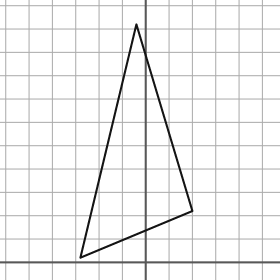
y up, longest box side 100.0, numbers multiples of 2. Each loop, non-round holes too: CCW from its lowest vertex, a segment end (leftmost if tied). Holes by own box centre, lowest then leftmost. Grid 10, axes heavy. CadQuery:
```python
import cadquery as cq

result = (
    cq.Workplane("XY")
    .moveTo(-28.0, 2.0)
    .lineTo(20.0, 22.0)
    .lineTo(-4.0, 102.0)
    .close()
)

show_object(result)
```